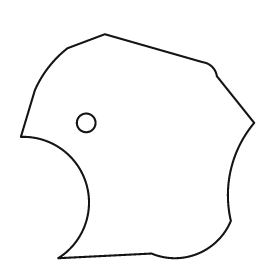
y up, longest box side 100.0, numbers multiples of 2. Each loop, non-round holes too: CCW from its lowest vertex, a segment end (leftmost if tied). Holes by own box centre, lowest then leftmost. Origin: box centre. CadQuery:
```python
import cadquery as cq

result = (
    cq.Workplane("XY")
    .moveTo(-34.0, -48.0)
    .lineTo(6.0, -46.0)
    .threePointArc((26.0, -46.0), (40.0, -32.0))
    .threePointArc((40.0, -10.0), (50.0, 10.0))
    .lineTo(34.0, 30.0)
    .threePointArc((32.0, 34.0), (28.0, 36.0))
    .lineTo(-14.0, 48.0)
    .lineTo(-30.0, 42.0)
    .threePointArc((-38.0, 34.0), (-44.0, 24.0))
    .lineTo(-50.0, 4.0)
    .threePointArc((-22.0, -16.0), (-34.0, -48.0))
    .close()
    .moveTo(-22.0, 10.0)
    .circle(4.0)
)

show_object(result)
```